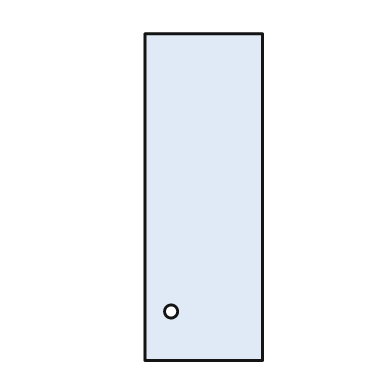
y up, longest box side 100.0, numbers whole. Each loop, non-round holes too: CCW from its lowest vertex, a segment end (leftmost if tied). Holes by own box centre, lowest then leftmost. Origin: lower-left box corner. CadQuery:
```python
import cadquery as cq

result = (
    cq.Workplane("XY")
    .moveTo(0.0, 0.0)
    .lineTo(36.0, 0.0)
    .lineTo(36.0, 100.0)
    .lineTo(0.0, 100.0)
    .close()
    .moveTo(8.0, 15.0)
    .circle(2.0)
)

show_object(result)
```